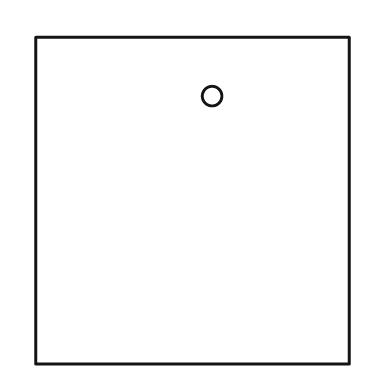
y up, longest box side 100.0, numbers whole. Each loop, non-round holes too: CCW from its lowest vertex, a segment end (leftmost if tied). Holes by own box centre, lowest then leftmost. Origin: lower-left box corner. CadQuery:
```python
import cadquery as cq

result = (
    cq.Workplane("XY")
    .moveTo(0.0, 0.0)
    .lineTo(96.0, 0.0)
    .lineTo(96.0, 100.0)
    .lineTo(0.0, 100.0)
    .close()
    .moveTo(54.0, 82.0)
    .circle(3.0)
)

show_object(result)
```